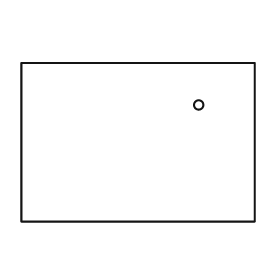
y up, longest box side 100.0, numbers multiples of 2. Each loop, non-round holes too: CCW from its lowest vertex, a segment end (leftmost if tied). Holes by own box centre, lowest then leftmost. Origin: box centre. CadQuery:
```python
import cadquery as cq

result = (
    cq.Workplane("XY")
    .moveTo(-50.0, -34.0)
    .lineTo(50.0, -34.0)
    .lineTo(50.0, 34.0)
    .lineTo(-50.0, 34.0)
    .close()
    .moveTo(26.0, 16.0)
    .circle(2.0)
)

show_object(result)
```